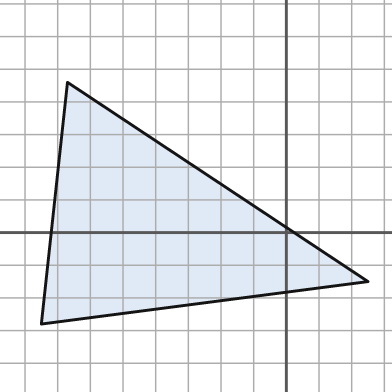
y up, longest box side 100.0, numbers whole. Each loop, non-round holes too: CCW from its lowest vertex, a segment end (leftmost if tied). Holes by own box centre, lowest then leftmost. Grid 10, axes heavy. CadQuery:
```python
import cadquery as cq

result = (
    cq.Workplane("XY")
    .moveTo(-75.0, -28.0)
    .lineTo(25.0, -15.0)
    .lineTo(-67.0, 46.0)
    .close()
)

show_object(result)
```